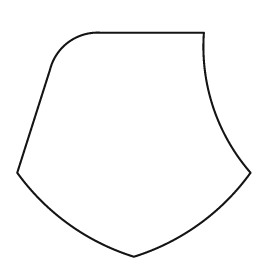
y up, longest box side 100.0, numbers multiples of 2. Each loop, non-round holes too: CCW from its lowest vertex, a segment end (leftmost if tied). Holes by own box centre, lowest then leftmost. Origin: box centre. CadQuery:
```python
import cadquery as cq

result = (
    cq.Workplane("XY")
    .moveTo(0.0, -48.0)
    .threePointArc((28.0, -34.0), (50.0, -12.0))
    .threePointArc((34.0, 16.0), (30.0, 48.0))
    .lineTo(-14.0, 48.0)
    .threePointArc((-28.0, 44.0), (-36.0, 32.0))
    .lineTo(-50.0, -12.0)
    .threePointArc((-28.0, -34.0), (0.0, -48.0))
    .close()
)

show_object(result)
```